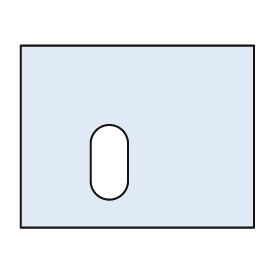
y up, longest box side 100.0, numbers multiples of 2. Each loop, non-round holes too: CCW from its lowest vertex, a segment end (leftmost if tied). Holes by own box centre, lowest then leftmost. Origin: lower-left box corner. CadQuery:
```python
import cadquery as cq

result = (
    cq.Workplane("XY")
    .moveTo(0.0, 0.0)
    .lineTo(100.0, 0.0)
    .lineTo(100.0, 78.0)
    .lineTo(0.0, 78.0)
    .close()
    .moveTo(30.0, 20.0)
    .threePointArc((38.0, 12.0), (46.0, 20.0))
    .lineTo(46.0, 36.0)
    .threePointArc((38.0, 44.0), (30.0, 36.0))
    .close()
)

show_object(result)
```